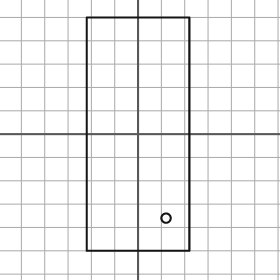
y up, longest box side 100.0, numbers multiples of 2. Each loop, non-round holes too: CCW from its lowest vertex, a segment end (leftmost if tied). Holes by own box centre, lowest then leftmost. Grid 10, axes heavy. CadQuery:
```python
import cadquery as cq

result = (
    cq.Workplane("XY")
    .moveTo(-22.0, -50.0)
    .lineTo(22.0, -50.0)
    .lineTo(22.0, 50.0)
    .lineTo(-22.0, 50.0)
    .close()
    .moveTo(12.0, -36.0)
    .circle(2.0)
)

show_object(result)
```